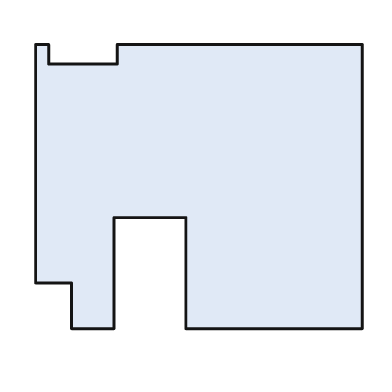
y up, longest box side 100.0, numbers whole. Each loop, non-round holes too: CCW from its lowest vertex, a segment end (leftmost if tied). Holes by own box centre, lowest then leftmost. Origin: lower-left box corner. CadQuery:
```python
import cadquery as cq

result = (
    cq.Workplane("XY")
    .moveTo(11.0, 0.0)
    .lineTo(24.0, 0.0)
    .lineTo(24.0, 34.0)
    .lineTo(46.0, 34.0)
    .lineTo(46.0, 0.0)
    .lineTo(100.0, 0.0)
    .lineTo(100.0, 87.0)
    .lineTo(25.0, 87.0)
    .lineTo(25.0, 81.0)
    .lineTo(4.0, 81.0)
    .lineTo(4.0, 87.0)
    .lineTo(0.0, 87.0)
    .lineTo(0.0, 14.0)
    .lineTo(11.0, 14.0)
    .close()
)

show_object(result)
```